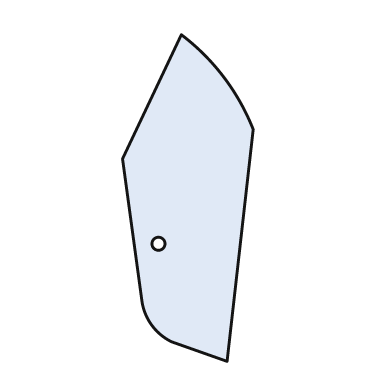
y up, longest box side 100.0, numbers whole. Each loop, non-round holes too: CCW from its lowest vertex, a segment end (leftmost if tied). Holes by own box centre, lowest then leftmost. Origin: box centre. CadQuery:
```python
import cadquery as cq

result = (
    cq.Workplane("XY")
    .moveTo(12.0, -50.0)
    .lineTo(20.0, 21.0)
    .threePointArc((11.0, 37.0), (-2.0, 50.0))
    .lineTo(-20.0, 12.0)
    .lineTo(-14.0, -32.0)
    .threePointArc((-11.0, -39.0), (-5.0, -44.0))
    .close()
    .moveTo(-9.0, -14.0)
    .circle(2.0)
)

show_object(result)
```